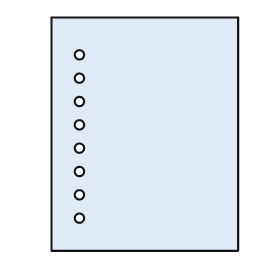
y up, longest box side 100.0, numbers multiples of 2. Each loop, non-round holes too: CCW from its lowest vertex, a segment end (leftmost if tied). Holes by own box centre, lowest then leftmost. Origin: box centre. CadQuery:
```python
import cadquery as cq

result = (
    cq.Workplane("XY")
    .moveTo(-40.0, -50.0)
    .lineTo(40.0, -50.0)
    .lineTo(40.0, 50.0)
    .lineTo(-40.0, 50.0)
    .close()
    .moveTo(-28.0, -36.0)
    .circle(2.0)
    .moveTo(-28.0, -26.0)
    .circle(2.0)
    .moveTo(-28.0, -16.0)
    .circle(2.0)
    .moveTo(-28.0, -6.0)
    .circle(2.0)
    .moveTo(-28.0, 4.0)
    .circle(2.0)
    .moveTo(-28.0, 14.0)
    .circle(2.0)
    .moveTo(-28.0, 24.0)
    .circle(2.0)
    .moveTo(-28.0, 34.0)
    .circle(2.0)
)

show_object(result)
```